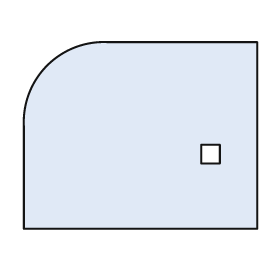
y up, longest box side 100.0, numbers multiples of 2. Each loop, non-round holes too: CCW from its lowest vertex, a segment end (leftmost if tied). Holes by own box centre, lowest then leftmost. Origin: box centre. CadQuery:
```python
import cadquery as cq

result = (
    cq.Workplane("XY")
    .moveTo(-50.0, -40.0)
    .lineTo(50.0, -40.0)
    .lineTo(50.0, 40.0)
    .lineTo(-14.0, 40.0)
    .threePointArc((-40.0, 30.0), (-50.0, 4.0))
    .close()
    .moveTo(26.0, -12.0)
    .lineTo(34.0, -12.0)
    .lineTo(34.0, -4.0)
    .lineTo(26.0, -4.0)
    .close()
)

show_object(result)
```